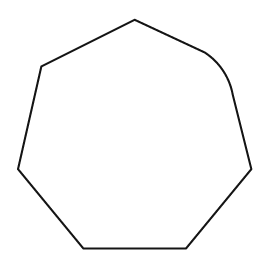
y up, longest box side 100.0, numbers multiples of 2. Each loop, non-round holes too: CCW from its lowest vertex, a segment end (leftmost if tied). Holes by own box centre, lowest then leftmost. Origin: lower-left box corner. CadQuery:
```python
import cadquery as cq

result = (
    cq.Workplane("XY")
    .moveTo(28.0, 0.0)
    .lineTo(72.0, 0.0)
    .lineTo(100.0, 34.0)
    .lineTo(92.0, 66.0)
    .threePointArc((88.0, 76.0), (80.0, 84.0))
    .lineTo(50.0, 98.0)
    .lineTo(10.0, 78.0)
    .lineTo(0.0, 34.0)
    .close()
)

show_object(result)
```